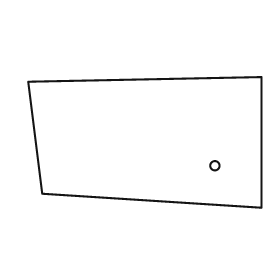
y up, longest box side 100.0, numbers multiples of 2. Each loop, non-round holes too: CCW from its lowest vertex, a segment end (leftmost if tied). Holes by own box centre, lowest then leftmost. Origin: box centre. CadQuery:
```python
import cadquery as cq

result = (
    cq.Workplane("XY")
    .moveTo(50.0, -28.0)
    .lineTo(50.0, 28.0)
    .lineTo(-50.0, 26.0)
    .lineTo(-44.0, -22.0)
    .close()
    .moveTo(30.0, -10.0)
    .circle(2.0)
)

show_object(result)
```